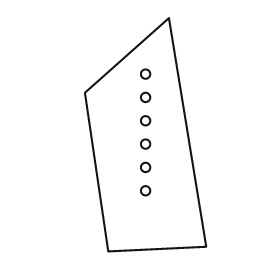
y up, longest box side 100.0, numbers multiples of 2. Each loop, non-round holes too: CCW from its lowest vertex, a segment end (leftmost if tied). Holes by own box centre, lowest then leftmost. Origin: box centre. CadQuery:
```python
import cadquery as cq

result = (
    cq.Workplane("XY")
    .moveTo(-16.0, -50.0)
    .lineTo(26.0, -48.0)
    .lineTo(10.0, 50.0)
    .lineTo(-26.0, 18.0)
    .close()
    .moveTo(0.0, -24.0)
    .circle(2.0)
    .moveTo(0.0, -14.0)
    .circle(2.0)
    .moveTo(0.0, -4.0)
    .circle(2.0)
    .moveTo(0.0, 6.0)
    .circle(2.0)
    .moveTo(0.0, 16.0)
    .circle(2.0)
    .moveTo(0.0, 26.0)
    .circle(2.0)
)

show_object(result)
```